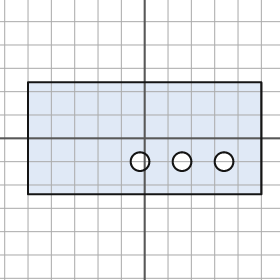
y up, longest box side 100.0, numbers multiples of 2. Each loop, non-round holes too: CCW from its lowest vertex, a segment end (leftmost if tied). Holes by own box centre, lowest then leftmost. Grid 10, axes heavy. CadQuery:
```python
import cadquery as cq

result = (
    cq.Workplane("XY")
    .moveTo(-50.0, -24.0)
    .lineTo(50.0, -24.0)
    .lineTo(50.0, 24.0)
    .lineTo(-50.0, 24.0)
    .close()
    .moveTo(-2.0, -10.0)
    .circle(4.0)
    .moveTo(16.0, -10.0)
    .circle(4.0)
    .moveTo(34.0, -10.0)
    .circle(4.0)
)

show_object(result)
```